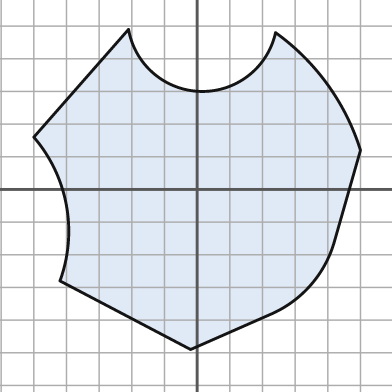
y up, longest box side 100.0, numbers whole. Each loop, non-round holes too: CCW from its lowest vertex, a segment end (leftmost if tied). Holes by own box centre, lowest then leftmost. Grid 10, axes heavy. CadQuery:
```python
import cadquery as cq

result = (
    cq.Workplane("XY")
    .moveTo(-2.0, -49.0)
    .lineTo(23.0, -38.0)
    .threePointArc((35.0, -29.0), (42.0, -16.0))
    .lineTo(50.0, 12.0)
    .threePointArc((40.0, 32.0), (24.0, 48.0))
    .threePointArc((1.0, 30.0), (-21.0, 49.0))
    .lineTo(-50.0, 16.0)
    .threePointArc((-40.0, -5.0), (-42.0, -28.0))
    .close()
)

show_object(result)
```